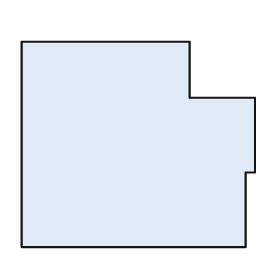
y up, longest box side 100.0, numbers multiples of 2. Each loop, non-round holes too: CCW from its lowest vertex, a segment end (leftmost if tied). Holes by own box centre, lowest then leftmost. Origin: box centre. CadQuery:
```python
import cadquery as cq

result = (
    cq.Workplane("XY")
    .moveTo(-50.0, -44.0)
    .lineTo(46.0, -44.0)
    .lineTo(46.0, -12.0)
    .lineTo(50.0, -12.0)
    .lineTo(50.0, 20.0)
    .lineTo(22.0, 20.0)
    .lineTo(22.0, 44.0)
    .lineTo(-50.0, 44.0)
    .close()
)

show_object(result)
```